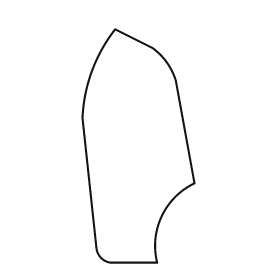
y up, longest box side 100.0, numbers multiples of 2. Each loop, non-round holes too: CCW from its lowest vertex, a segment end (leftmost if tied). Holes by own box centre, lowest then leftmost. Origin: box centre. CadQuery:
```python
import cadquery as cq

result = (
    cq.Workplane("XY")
    .moveTo(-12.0, -50.0)
    .lineTo(8.0, -50.0)
    .threePointArc((10.0, -30.0), (24.0, -16.0))
    .lineTo(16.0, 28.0)
    .threePointArc((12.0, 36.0), (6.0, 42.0))
    .lineTo(-10.0, 50.0)
    .threePointArc((-20.0, 32.0), (-24.0, 12.0))
    .lineTo(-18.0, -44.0)
    .threePointArc((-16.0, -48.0), (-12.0, -50.0))
    .close()
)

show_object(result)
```